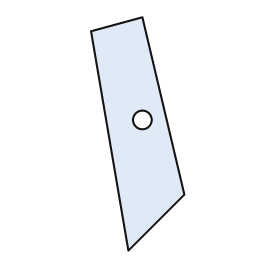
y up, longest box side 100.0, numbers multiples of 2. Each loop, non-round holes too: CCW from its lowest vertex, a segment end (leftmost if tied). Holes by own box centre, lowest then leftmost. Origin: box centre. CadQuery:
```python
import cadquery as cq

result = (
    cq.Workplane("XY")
    .moveTo(-4.0, -50.0)
    .lineTo(20.0, -26.0)
    .lineTo(2.0, 50.0)
    .lineTo(-20.0, 44.0)
    .close()
    .moveTo(2.0, 6.0)
    .circle(4.0)
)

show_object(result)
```